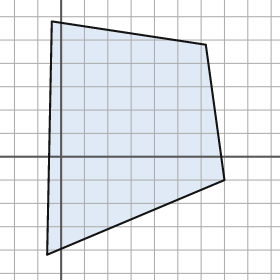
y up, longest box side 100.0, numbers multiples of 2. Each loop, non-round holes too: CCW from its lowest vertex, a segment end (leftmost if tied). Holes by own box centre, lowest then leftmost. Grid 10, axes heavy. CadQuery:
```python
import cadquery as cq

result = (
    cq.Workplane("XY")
    .moveTo(-6.0, -42.0)
    .lineTo(70.0, -10.0)
    .lineTo(62.0, 48.0)
    .lineTo(-4.0, 58.0)
    .close()
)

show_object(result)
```